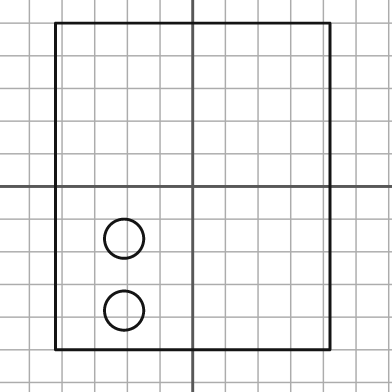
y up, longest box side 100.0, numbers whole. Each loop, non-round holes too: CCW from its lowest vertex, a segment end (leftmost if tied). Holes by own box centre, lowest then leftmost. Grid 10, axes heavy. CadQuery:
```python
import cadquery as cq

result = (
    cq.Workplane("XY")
    .moveTo(-42.0, -50.0)
    .lineTo(42.0, -50.0)
    .lineTo(42.0, 50.0)
    .lineTo(-42.0, 50.0)
    .close()
    .moveTo(-21.0, -38.0)
    .circle(6.0)
    .moveTo(-21.0, -16.0)
    .circle(6.0)
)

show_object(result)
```